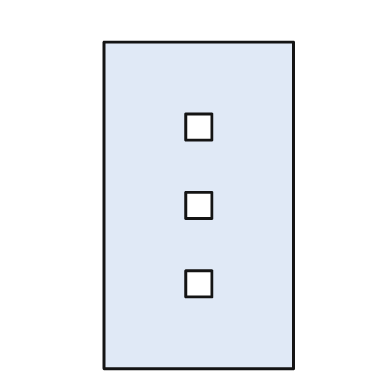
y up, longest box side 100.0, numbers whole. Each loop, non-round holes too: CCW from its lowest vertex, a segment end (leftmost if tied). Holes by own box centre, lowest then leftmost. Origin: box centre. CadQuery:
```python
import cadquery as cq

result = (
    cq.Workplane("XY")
    .moveTo(-29.0, -50.0)
    .lineTo(29.0, -50.0)
    .lineTo(29.0, 50.0)
    .lineTo(-29.0, 50.0)
    .close()
    .moveTo(-4.0, -28.0)
    .lineTo(4.0, -28.0)
    .lineTo(4.0, -20.0)
    .lineTo(-4.0, -20.0)
    .close()
    .moveTo(-4.0, -4.0)
    .lineTo(4.0, -4.0)
    .lineTo(4.0, 4.0)
    .lineTo(-4.0, 4.0)
    .close()
    .moveTo(-4.0, 20.0)
    .lineTo(4.0, 20.0)
    .lineTo(4.0, 28.0)
    .lineTo(-4.0, 28.0)
    .close()
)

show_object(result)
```